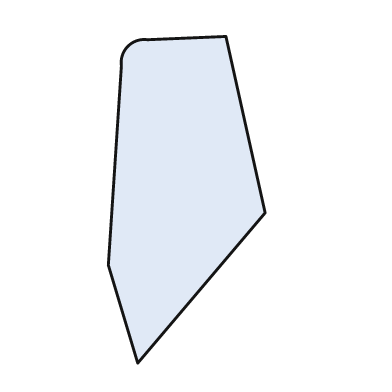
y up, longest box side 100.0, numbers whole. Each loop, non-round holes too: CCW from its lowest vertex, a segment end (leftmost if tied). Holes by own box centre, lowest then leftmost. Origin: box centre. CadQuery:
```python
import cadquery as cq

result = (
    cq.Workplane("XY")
    .moveTo(-15.0, -50.0)
    .lineTo(24.0, -4.0)
    .lineTo(12.0, 50.0)
    .lineTo(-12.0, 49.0)
    .threePointArc((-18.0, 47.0), (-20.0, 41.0))
    .lineTo(-24.0, -20.0)
    .close()
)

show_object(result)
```